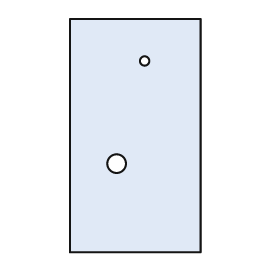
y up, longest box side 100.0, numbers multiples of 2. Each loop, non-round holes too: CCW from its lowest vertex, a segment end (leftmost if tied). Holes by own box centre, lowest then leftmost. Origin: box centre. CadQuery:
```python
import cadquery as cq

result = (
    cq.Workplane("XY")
    .moveTo(-28.0, -50.0)
    .lineTo(28.0, -50.0)
    .lineTo(28.0, 50.0)
    .lineTo(-28.0, 50.0)
    .close()
    .moveTo(-8.0, -12.0)
    .circle(4.0)
    .moveTo(4.0, 32.0)
    .circle(2.0)
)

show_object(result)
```